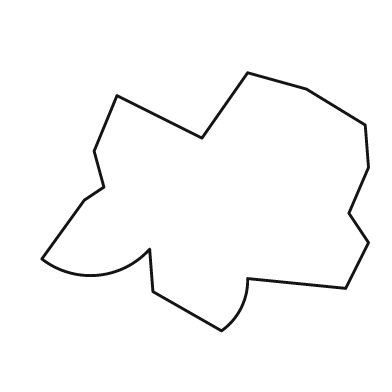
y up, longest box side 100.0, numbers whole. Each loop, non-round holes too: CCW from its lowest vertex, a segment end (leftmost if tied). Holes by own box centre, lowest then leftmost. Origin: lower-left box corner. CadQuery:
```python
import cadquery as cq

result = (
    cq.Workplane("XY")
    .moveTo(55.0, 0.0)
    .threePointArc((61.0, 7.0), (63.0, 16.0))
    .lineTo(93.0, 13.0)
    .lineTo(100.0, 27.0)
    .lineTo(94.0, 36.0)
    .lineTo(100.0, 50.0)
    .lineTo(99.0, 63.0)
    .lineTo(81.0, 74.0)
    .lineTo(63.0, 79.0)
    .lineTo(49.0, 59.0)
    .lineTo(23.0, 72.0)
    .lineTo(16.0, 55.0)
    .lineTo(19.0, 44.0)
    .lineTo(13.0, 40.0)
    .lineTo(0.0, 22.0)
    .threePointArc((17.0, 17.0), (33.0, 25.0))
    .lineTo(34.0, 12.0)
    .close()
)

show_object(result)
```